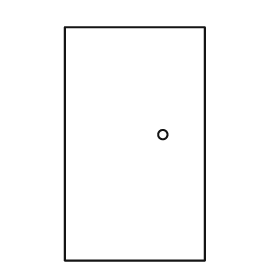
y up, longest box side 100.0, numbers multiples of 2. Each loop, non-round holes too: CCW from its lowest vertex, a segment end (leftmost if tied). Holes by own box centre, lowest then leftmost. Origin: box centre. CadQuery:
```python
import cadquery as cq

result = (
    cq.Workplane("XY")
    .moveTo(-30.0, -50.0)
    .lineTo(30.0, -50.0)
    .lineTo(30.0, 50.0)
    .lineTo(-30.0, 50.0)
    .close()
    .moveTo(12.0, 4.0)
    .circle(2.0)
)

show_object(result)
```